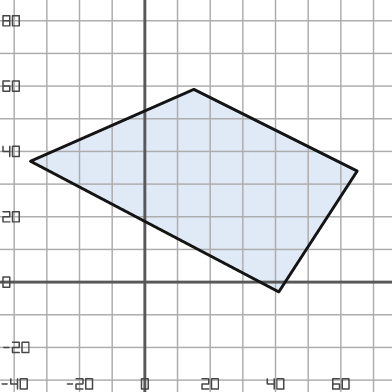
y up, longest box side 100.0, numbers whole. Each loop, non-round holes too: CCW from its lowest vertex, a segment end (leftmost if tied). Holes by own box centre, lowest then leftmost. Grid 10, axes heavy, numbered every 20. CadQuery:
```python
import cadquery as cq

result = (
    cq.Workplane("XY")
    .moveTo(41.0, -3.0)
    .lineTo(65.0, 34.0)
    .lineTo(15.0, 59.0)
    .lineTo(-35.0, 37.0)
    .close()
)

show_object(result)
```